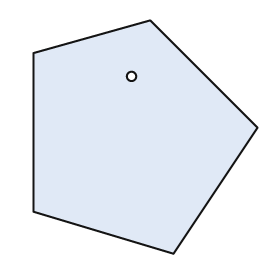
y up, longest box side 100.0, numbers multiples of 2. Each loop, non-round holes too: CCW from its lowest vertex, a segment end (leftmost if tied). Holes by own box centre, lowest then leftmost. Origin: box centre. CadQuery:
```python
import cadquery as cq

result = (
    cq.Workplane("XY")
    .moveTo(12.0, -50.0)
    .lineTo(48.0, 4.0)
    .lineTo(2.0, 50.0)
    .lineTo(-48.0, 36.0)
    .lineTo(-48.0, -32.0)
    .close()
    .moveTo(-6.0, 26.0)
    .circle(2.0)
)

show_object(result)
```